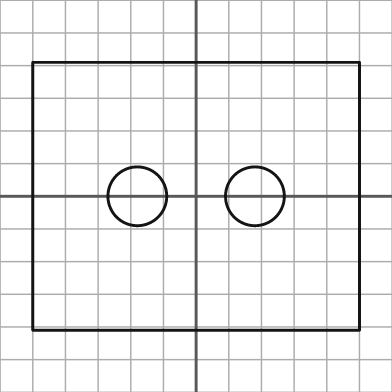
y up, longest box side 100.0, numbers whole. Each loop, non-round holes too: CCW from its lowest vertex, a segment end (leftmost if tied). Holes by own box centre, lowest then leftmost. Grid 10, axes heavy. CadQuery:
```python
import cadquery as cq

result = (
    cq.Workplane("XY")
    .moveTo(-50.0, -41.0)
    .lineTo(50.0, -41.0)
    .lineTo(50.0, 41.0)
    .lineTo(-50.0, 41.0)
    .close()
    .moveTo(-18.0, 0.0)
    .circle(9.0)
    .moveTo(18.0, 0.0)
    .circle(9.0)
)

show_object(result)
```